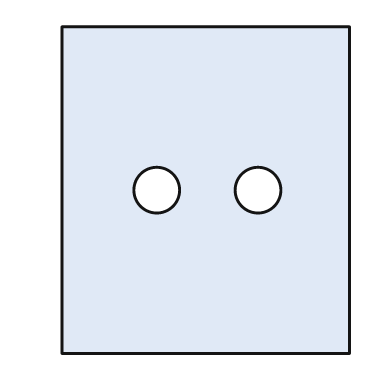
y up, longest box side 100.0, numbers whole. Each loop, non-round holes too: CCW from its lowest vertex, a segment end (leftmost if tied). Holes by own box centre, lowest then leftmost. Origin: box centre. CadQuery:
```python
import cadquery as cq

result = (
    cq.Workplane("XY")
    .moveTo(-44.0, -50.0)
    .lineTo(44.0, -50.0)
    .lineTo(44.0, 50.0)
    .lineTo(-44.0, 50.0)
    .close()
    .moveTo(-15.0, 0.0)
    .circle(7.0)
    .moveTo(16.0, 0.0)
    .circle(7.0)
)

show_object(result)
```